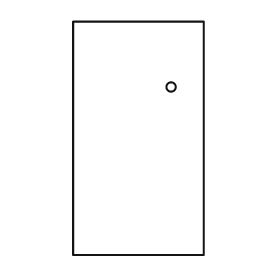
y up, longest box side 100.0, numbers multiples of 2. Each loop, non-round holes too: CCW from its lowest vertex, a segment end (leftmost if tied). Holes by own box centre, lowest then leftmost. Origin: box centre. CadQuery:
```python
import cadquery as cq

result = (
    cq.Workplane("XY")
    .moveTo(-28.0, -50.0)
    .lineTo(28.0, -50.0)
    .lineTo(28.0, 50.0)
    .lineTo(-28.0, 50.0)
    .close()
    .moveTo(14.0, 22.0)
    .circle(2.0)
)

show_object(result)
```